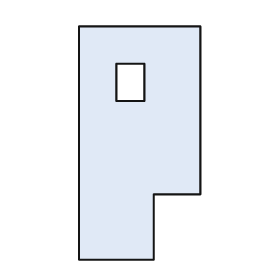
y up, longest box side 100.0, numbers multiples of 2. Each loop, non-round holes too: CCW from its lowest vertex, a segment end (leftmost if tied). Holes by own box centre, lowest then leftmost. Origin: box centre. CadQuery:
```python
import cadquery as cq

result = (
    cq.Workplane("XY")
    .moveTo(-26.0, -50.0)
    .lineTo(6.0, -50.0)
    .lineTo(6.0, -22.0)
    .lineTo(26.0, -22.0)
    .lineTo(26.0, 50.0)
    .lineTo(-26.0, 50.0)
    .close()
    .moveTo(-10.0, 18.0)
    .lineTo(2.0, 18.0)
    .lineTo(2.0, 34.0)
    .lineTo(-10.0, 34.0)
    .close()
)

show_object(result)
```